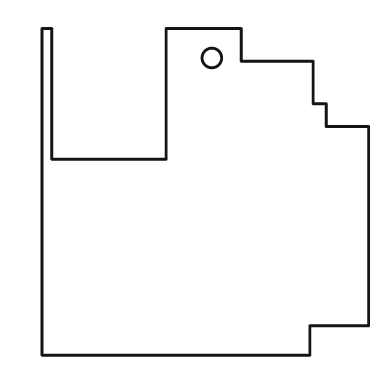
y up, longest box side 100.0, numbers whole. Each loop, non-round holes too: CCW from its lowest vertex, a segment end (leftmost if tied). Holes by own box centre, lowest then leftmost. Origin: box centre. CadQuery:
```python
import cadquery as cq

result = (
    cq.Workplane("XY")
    .moveTo(-50.0, -50.0)
    .lineTo(32.0, -50.0)
    .lineTo(32.0, -41.0)
    .lineTo(50.0, -41.0)
    .lineTo(50.0, 20.0)
    .lineTo(37.0, 20.0)
    .lineTo(37.0, 27.0)
    .lineTo(33.0, 27.0)
    .lineTo(33.0, 40.0)
    .lineTo(11.0, 40.0)
    .lineTo(11.0, 50.0)
    .lineTo(-12.0, 50.0)
    .lineTo(-12.0, 10.0)
    .lineTo(-47.0, 10.0)
    .lineTo(-47.0, 50.0)
    .lineTo(-50.0, 50.0)
    .close()
    .moveTo(2.0, 41.0)
    .circle(3.0)
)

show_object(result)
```